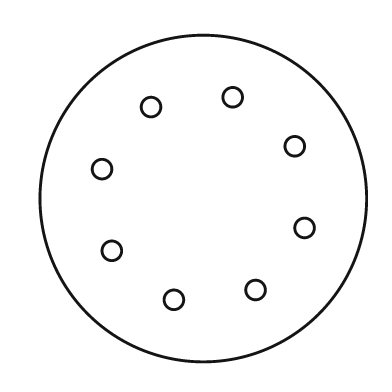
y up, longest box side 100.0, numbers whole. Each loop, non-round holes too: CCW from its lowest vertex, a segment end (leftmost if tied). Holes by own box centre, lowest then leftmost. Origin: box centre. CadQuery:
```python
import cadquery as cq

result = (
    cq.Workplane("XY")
    .moveTo(0.0, 0.0)
    .circle(50.0)
    .moveTo(-9.0, -31.0)
    .circle(3.0)
    .moveTo(16.0, -28.0)
    .circle(3.0)
    .moveTo(-28.0, -16.0)
    .circle(3.0)
    .moveTo(31.0, -9.0)
    .circle(3.0)
    .moveTo(-31.0, 9.0)
    .circle(3.0)
    .moveTo(28.0, 16.0)
    .circle(3.0)
    .moveTo(-16.0, 28.0)
    .circle(3.0)
    .moveTo(9.0, 31.0)
    .circle(3.0)
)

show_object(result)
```